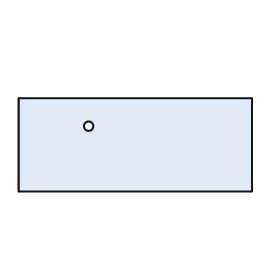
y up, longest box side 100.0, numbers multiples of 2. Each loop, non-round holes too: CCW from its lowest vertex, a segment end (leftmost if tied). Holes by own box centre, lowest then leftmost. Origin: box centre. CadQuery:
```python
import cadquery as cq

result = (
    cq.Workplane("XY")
    .moveTo(-50.0, -20.0)
    .lineTo(50.0, -20.0)
    .lineTo(50.0, 20.0)
    .lineTo(-50.0, 20.0)
    .close()
    .moveTo(-20.0, 8.0)
    .circle(2.0)
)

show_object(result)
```